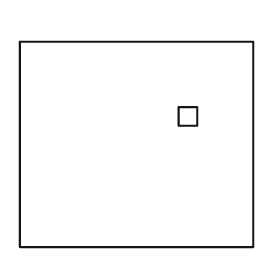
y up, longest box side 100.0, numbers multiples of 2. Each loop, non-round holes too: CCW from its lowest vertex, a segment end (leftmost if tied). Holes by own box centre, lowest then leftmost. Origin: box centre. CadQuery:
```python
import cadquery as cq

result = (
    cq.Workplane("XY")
    .moveTo(-50.0, -44.0)
    .lineTo(50.0, -44.0)
    .lineTo(50.0, 44.0)
    .lineTo(-50.0, 44.0)
    .close()
    .moveTo(18.0, 8.0)
    .lineTo(26.0, 8.0)
    .lineTo(26.0, 16.0)
    .lineTo(18.0, 16.0)
    .close()
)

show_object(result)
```